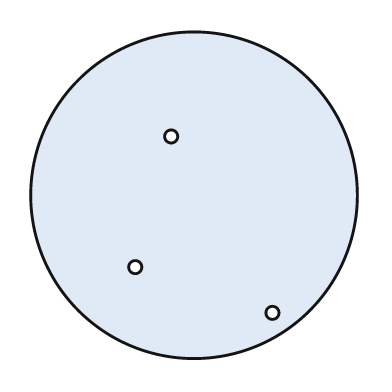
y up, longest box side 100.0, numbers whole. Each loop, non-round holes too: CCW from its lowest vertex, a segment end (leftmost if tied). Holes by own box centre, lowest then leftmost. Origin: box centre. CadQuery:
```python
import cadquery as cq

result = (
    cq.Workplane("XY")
    .moveTo(0.0, 0.0)
    .circle(50.0)
    .moveTo(24.0, -36.0)
    .circle(2.0)
    .moveTo(-18.0, -22.0)
    .circle(2.0)
    .moveTo(-7.0, 18.0)
    .circle(2.0)
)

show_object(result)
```